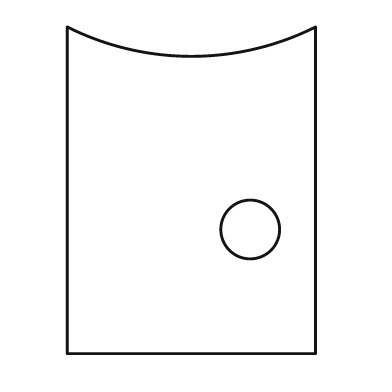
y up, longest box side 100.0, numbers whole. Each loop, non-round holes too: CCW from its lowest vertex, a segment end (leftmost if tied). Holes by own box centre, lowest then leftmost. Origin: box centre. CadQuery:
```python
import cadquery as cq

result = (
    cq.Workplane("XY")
    .moveTo(-38.0, -50.0)
    .lineTo(38.0, -50.0)
    .lineTo(38.0, 50.0)
    .threePointArc((0.0, 41.0), (-38.0, 50.0))
    .close()
    .moveTo(18.0, -12.0)
    .circle(9.0)
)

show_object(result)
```